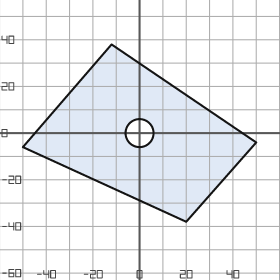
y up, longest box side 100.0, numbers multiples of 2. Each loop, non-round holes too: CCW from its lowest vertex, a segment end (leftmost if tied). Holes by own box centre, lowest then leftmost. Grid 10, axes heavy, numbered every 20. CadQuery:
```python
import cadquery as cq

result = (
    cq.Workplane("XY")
    .moveTo(20.0, -38.0)
    .lineTo(50.0, -4.0)
    .lineTo(-12.0, 38.0)
    .lineTo(-50.0, -6.0)
    .close()
    .moveTo(0.0, 0.0)
    .circle(6.0)
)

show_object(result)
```